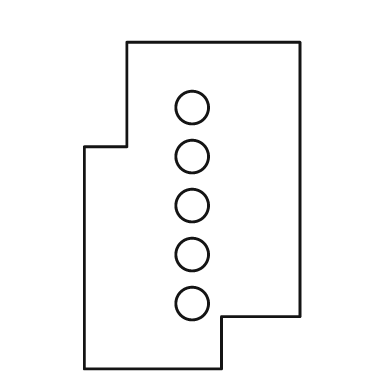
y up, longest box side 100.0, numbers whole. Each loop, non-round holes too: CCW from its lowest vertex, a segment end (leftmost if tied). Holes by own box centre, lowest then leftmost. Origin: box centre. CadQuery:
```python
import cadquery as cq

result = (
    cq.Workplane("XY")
    .moveTo(-33.0, -50.0)
    .lineTo(9.0, -50.0)
    .lineTo(9.0, -34.0)
    .lineTo(33.0, -34.0)
    .lineTo(33.0, 50.0)
    .lineTo(-20.0, 50.0)
    .lineTo(-20.0, 18.0)
    .lineTo(-33.0, 18.0)
    .close()
    .moveTo(0.0, -30.0)
    .circle(5.0)
    .moveTo(0.0, -15.0)
    .circle(5.0)
    .moveTo(0.0, 0.0)
    .circle(5.0)
    .moveTo(0.0, 15.0)
    .circle(5.0)
    .moveTo(0.0, 30.0)
    .circle(5.0)
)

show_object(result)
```